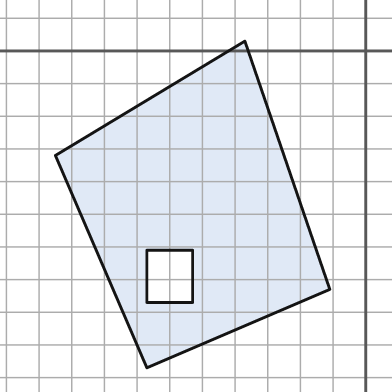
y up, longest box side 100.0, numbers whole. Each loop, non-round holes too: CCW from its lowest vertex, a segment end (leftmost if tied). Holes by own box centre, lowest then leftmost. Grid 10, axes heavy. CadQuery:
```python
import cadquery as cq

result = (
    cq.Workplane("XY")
    .moveTo(-67.0, -97.0)
    .lineTo(-11.0, -73.0)
    .lineTo(-37.0, 3.0)
    .lineTo(-95.0, -32.0)
    .close()
    .moveTo(-67.0, -77.0)
    .lineTo(-53.0, -77.0)
    .lineTo(-53.0, -61.0)
    .lineTo(-67.0, -61.0)
    .close()
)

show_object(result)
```